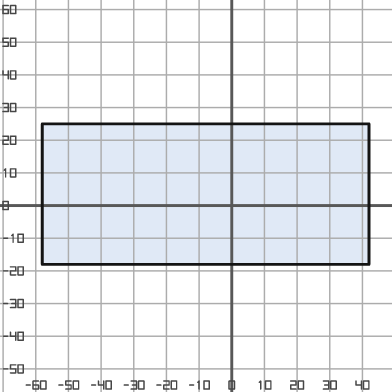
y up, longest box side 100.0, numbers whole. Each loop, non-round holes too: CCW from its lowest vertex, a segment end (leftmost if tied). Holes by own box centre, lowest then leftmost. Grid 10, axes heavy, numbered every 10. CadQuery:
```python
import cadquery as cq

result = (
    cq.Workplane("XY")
    .moveTo(-58.0, -18.0)
    .lineTo(42.0, -18.0)
    .lineTo(42.0, 25.0)
    .lineTo(-58.0, 25.0)
    .close()
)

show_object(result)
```